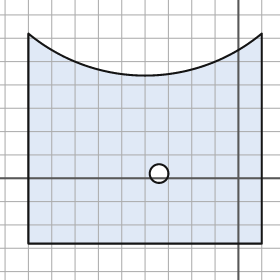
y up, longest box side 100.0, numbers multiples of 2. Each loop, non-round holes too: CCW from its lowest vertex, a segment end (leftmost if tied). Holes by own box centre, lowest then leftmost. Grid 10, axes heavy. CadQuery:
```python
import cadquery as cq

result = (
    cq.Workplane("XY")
    .moveTo(-90.0, -28.0)
    .lineTo(10.0, -28.0)
    .lineTo(10.0, 62.0)
    .threePointArc((-40.0, 44.0), (-90.0, 62.0))
    .close()
    .moveTo(-34.0, 2.0)
    .circle(4.0)
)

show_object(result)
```